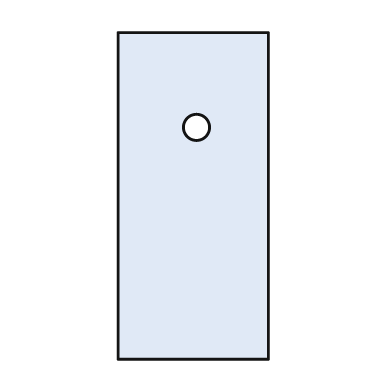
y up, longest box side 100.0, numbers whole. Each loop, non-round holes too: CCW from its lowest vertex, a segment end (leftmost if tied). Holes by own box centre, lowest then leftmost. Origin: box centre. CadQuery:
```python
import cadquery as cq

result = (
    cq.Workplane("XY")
    .moveTo(-23.0, -50.0)
    .lineTo(23.0, -50.0)
    .lineTo(23.0, 50.0)
    .lineTo(-23.0, 50.0)
    .close()
    .moveTo(1.0, 21.0)
    .circle(4.0)
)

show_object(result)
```